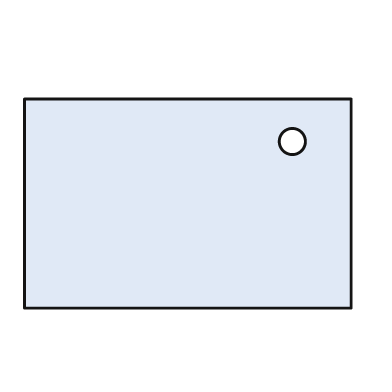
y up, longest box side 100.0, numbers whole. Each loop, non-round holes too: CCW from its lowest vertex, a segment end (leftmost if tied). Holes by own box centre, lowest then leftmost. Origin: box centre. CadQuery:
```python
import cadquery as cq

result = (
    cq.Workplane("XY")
    .moveTo(-50.0, -32.0)
    .lineTo(50.0, -32.0)
    .lineTo(50.0, 32.0)
    .lineTo(-50.0, 32.0)
    .close()
    .moveTo(32.0, 19.0)
    .circle(4.0)
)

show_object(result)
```